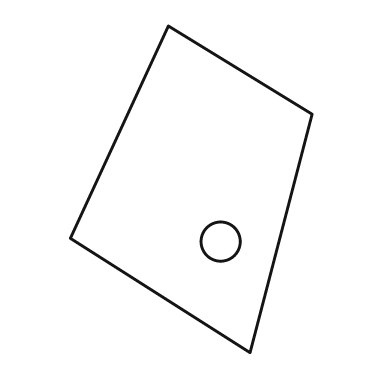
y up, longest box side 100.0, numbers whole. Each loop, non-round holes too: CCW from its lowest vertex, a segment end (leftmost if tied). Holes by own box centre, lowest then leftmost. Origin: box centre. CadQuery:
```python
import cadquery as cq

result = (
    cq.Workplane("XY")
    .moveTo(18.0, -50.0)
    .lineTo(37.0, 23.0)
    .lineTo(-7.0, 50.0)
    .lineTo(-37.0, -15.0)
    .close()
    .moveTo(9.0, -16.0)
    .circle(6.0)
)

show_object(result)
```